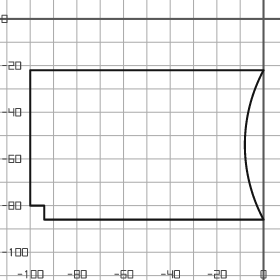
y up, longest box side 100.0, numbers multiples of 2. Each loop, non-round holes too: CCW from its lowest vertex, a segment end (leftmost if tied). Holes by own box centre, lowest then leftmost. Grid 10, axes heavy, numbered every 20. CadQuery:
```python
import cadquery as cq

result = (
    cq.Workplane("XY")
    .moveTo(-94.0, -86.0)
    .lineTo(0.0, -86.0)
    .threePointArc((-8.0, -54.0), (0.0, -22.0))
    .lineTo(-100.0, -22.0)
    .lineTo(-100.0, -80.0)
    .lineTo(-94.0, -80.0)
    .close()
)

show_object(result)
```